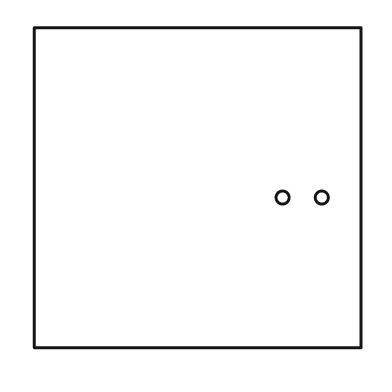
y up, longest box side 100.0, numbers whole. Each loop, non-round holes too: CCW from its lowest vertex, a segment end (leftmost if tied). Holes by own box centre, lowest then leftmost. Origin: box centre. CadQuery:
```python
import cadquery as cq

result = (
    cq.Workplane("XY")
    .moveTo(-50.0, -49.0)
    .lineTo(50.0, -49.0)
    .lineTo(50.0, 49.0)
    .lineTo(-50.0, 49.0)
    .close()
    .moveTo(26.0, -3.0)
    .circle(2.0)
    .moveTo(38.0, -3.0)
    .circle(2.0)
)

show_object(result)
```